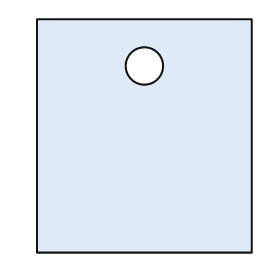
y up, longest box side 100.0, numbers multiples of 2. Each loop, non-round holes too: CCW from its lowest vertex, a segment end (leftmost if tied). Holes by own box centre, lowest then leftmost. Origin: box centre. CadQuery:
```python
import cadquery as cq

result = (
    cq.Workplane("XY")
    .moveTo(-46.0, -50.0)
    .lineTo(46.0, -50.0)
    .lineTo(46.0, 50.0)
    .lineTo(-46.0, 50.0)
    .close()
    .moveTo(0.0, 30.0)
    .circle(8.0)
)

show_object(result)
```